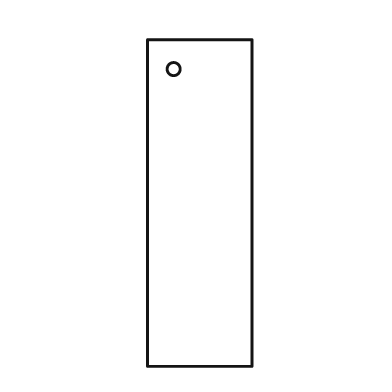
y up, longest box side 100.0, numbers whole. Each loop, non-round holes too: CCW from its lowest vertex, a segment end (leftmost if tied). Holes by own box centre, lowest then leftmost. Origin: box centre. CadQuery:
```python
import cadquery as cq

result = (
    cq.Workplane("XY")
    .moveTo(-16.0, -50.0)
    .lineTo(16.0, -50.0)
    .lineTo(16.0, 50.0)
    .lineTo(-16.0, 50.0)
    .close()
    .moveTo(-8.0, 41.0)
    .circle(2.0)
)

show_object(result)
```